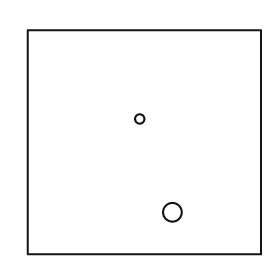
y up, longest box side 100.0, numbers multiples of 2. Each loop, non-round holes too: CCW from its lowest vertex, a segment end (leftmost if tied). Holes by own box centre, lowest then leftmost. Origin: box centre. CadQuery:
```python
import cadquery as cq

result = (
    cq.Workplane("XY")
    .moveTo(-50.0, -48.0)
    .lineTo(50.0, -48.0)
    .lineTo(50.0, 48.0)
    .lineTo(-50.0, 48.0)
    .close()
    .moveTo(12.0, -30.0)
    .circle(4.0)
    .moveTo(-2.0, 10.0)
    .circle(2.0)
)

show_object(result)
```